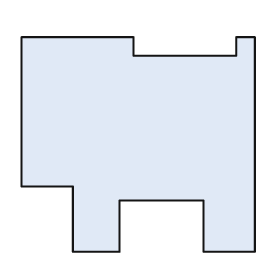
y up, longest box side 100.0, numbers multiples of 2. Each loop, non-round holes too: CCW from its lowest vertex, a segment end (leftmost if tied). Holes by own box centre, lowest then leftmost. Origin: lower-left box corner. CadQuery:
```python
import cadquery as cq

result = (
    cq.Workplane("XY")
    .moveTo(22.0, 0.0)
    .lineTo(42.0, 0.0)
    .lineTo(42.0, 22.0)
    .lineTo(78.0, 22.0)
    .lineTo(78.0, 0.0)
    .lineTo(100.0, 0.0)
    .lineTo(100.0, 92.0)
    .lineTo(92.0, 92.0)
    .lineTo(92.0, 84.0)
    .lineTo(48.0, 84.0)
    .lineTo(48.0, 92.0)
    .lineTo(0.0, 92.0)
    .lineTo(0.0, 28.0)
    .lineTo(22.0, 28.0)
    .close()
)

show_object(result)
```